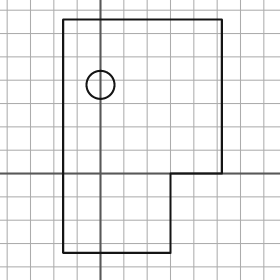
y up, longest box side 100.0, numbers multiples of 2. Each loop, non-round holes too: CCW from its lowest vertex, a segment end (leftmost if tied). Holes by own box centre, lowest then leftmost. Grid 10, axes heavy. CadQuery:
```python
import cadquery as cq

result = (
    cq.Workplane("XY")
    .moveTo(-16.0, -34.0)
    .lineTo(30.0, -34.0)
    .lineTo(30.0, 0.0)
    .lineTo(52.0, 0.0)
    .lineTo(52.0, 66.0)
    .lineTo(-16.0, 66.0)
    .close()
    .moveTo(0.0, 38.0)
    .circle(6.0)
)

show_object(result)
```